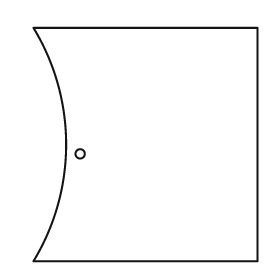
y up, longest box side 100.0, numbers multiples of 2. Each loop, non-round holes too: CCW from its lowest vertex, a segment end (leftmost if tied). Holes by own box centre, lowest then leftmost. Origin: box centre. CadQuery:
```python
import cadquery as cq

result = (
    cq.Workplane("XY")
    .moveTo(-48.0, -50.0)
    .lineTo(48.0, -50.0)
    .lineTo(48.0, 50.0)
    .lineTo(-48.0, 50.0)
    .threePointArc((-34.0, 0.0), (-48.0, -50.0))
    .close()
    .moveTo(-28.0, -4.0)
    .circle(2.0)
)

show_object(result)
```